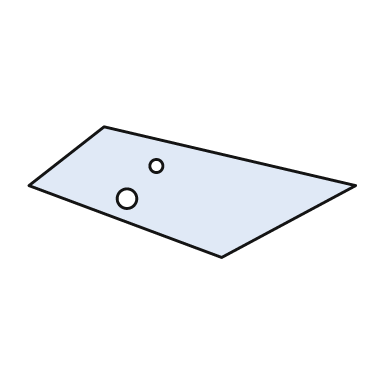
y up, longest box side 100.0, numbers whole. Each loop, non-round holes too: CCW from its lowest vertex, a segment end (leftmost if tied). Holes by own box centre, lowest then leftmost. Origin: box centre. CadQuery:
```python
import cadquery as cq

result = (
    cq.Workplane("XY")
    .moveTo(9.0, -20.0)
    .lineTo(50.0, 2.0)
    .lineTo(-27.0, 20.0)
    .lineTo(-50.0, 2.0)
    .close()
    .moveTo(-20.0, -2.0)
    .circle(3.0)
    .moveTo(-11.0, 8.0)
    .circle(2.0)
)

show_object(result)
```